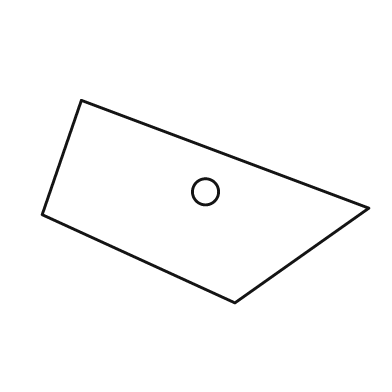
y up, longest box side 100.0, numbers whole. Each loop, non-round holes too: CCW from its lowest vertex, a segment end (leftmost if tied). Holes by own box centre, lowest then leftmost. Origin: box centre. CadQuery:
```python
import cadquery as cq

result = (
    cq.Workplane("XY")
    .moveTo(9.0, -31.0)
    .lineTo(50.0, -2.0)
    .lineTo(-38.0, 31.0)
    .lineTo(-50.0, -4.0)
    .close()
    .moveTo(0.0, 3.0)
    .circle(4.0)
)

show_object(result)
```